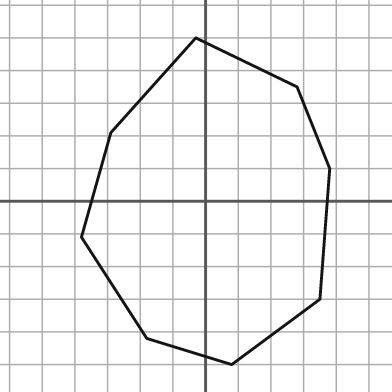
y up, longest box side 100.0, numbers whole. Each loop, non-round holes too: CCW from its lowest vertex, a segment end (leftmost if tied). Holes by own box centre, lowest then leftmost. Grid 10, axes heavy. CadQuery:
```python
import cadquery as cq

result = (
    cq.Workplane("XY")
    .moveTo(8.0, -50.0)
    .lineTo(35.0, -30.0)
    .lineTo(38.0, 10.0)
    .lineTo(28.0, 35.0)
    .lineTo(-3.0, 50.0)
    .lineTo(-29.0, 21.0)
    .lineTo(-38.0, -11.0)
    .lineTo(-18.0, -42.0)
    .close()
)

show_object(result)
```